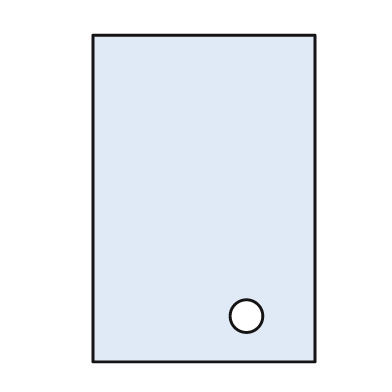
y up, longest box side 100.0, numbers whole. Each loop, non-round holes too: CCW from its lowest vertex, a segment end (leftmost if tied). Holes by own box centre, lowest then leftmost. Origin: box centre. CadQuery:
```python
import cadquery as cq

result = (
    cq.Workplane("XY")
    .moveTo(-34.0, -50.0)
    .lineTo(34.0, -50.0)
    .lineTo(34.0, 50.0)
    .lineTo(-34.0, 50.0)
    .close()
    .moveTo(13.0, -36.0)
    .circle(5.0)
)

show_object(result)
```